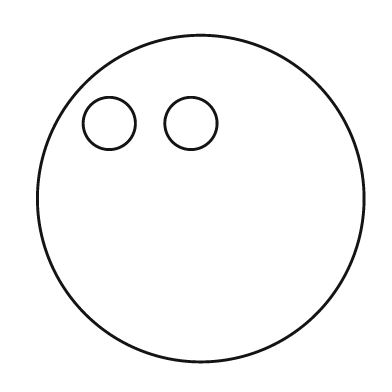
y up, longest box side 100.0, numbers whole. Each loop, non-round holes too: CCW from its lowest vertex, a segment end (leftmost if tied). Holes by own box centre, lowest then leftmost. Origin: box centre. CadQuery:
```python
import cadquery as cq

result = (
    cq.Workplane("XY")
    .moveTo(0.0, 0.0)
    .circle(50.0)
    .moveTo(-28.0, 23.0)
    .circle(8.0)
    .moveTo(-3.0, 23.0)
    .circle(8.0)
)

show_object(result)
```